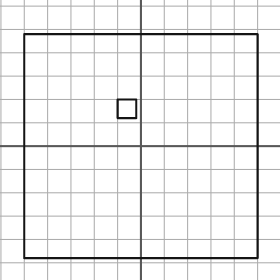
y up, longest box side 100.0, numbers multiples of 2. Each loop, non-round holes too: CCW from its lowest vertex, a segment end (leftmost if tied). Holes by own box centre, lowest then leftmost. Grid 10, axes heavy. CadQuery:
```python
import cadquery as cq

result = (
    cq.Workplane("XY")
    .moveTo(-50.0, -48.0)
    .lineTo(50.0, -48.0)
    .lineTo(50.0, 48.0)
    .lineTo(-50.0, 48.0)
    .close()
    .moveTo(-10.0, 12.0)
    .lineTo(-2.0, 12.0)
    .lineTo(-2.0, 20.0)
    .lineTo(-10.0, 20.0)
    .close()
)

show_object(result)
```